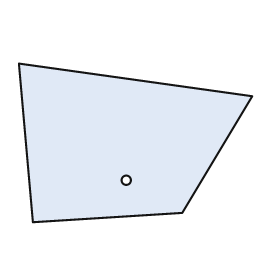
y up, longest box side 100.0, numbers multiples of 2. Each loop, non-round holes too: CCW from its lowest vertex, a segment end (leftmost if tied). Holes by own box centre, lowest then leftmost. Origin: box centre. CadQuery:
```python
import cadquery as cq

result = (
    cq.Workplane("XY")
    .moveTo(-44.0, -34.0)
    .lineTo(20.0, -30.0)
    .lineTo(50.0, 20.0)
    .lineTo(-50.0, 34.0)
    .close()
    .moveTo(-4.0, -16.0)
    .circle(2.0)
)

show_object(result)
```